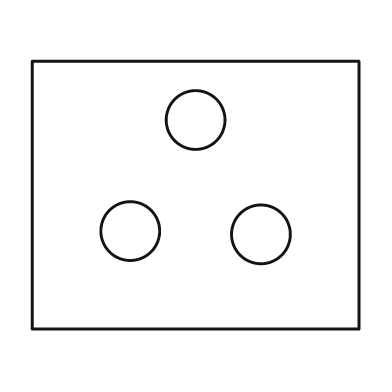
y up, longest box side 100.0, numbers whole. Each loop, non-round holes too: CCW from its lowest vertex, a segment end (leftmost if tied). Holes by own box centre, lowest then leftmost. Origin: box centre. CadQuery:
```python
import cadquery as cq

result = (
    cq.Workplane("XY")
    .moveTo(-50.0, -41.0)
    .lineTo(50.0, -41.0)
    .lineTo(50.0, 41.0)
    .lineTo(-50.0, 41.0)
    .close()
    .moveTo(20.0, -12.0)
    .circle(9.0)
    .moveTo(-20.0, -11.0)
    .circle(9.0)
    .moveTo(0.0, 23.0)
    .circle(9.0)
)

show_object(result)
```